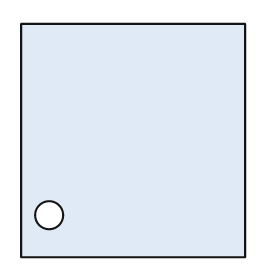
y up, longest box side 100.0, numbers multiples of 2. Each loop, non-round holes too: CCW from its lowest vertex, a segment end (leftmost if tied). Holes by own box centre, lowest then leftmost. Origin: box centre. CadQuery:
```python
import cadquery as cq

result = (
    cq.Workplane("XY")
    .moveTo(-48.0, -50.0)
    .lineTo(48.0, -50.0)
    .lineTo(48.0, 50.0)
    .lineTo(-48.0, 50.0)
    .close()
    .moveTo(-36.0, -32.0)
    .circle(6.0)
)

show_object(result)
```